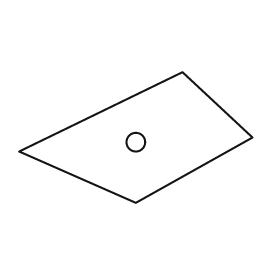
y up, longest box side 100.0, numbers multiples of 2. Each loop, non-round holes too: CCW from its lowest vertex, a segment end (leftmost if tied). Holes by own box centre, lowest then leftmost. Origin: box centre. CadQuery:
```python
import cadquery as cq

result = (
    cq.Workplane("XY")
    .moveTo(0.0, -28.0)
    .lineTo(50.0, 0.0)
    .lineTo(20.0, 28.0)
    .lineTo(-50.0, -6.0)
    .close()
    .moveTo(0.0, -2.0)
    .circle(4.0)
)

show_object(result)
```